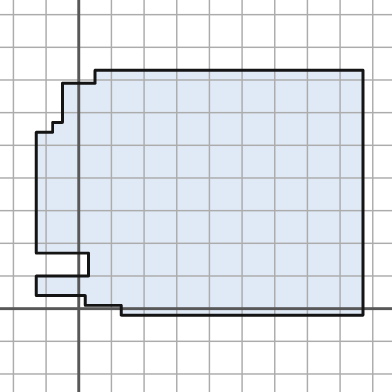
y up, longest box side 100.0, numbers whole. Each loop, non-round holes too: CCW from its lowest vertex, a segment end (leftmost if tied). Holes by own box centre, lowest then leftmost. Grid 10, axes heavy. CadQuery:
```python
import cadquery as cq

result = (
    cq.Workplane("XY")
    .moveTo(13.0, -2.0)
    .lineTo(87.0, -2.0)
    .lineTo(87.0, 73.0)
    .lineTo(5.0, 73.0)
    .lineTo(5.0, 69.0)
    .lineTo(-5.0, 69.0)
    .lineTo(-5.0, 57.0)
    .lineTo(-8.0, 57.0)
    .lineTo(-8.0, 54.0)
    .lineTo(-13.0, 54.0)
    .lineTo(-13.0, 17.0)
    .lineTo(3.0, 17.0)
    .lineTo(3.0, 10.0)
    .lineTo(-13.0, 10.0)
    .lineTo(-13.0, 4.0)
    .lineTo(2.0, 4.0)
    .lineTo(2.0, 1.0)
    .lineTo(13.0, 1.0)
    .close()
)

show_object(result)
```